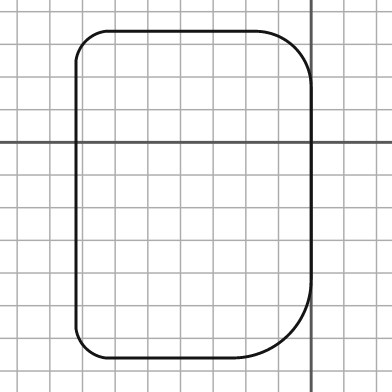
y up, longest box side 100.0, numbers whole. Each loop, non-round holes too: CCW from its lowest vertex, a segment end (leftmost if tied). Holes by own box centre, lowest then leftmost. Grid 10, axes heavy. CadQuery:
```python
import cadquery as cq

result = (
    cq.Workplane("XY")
    .moveTo(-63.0, -66.0)
    .lineTo(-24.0, -66.0)
    .threePointArc((-7.0, -59.0), (0.0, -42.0))
    .lineTo(0.0, 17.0)
    .threePointArc((-5.0, 29.0), (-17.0, 34.0))
    .lineTo(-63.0, 34.0)
    .threePointArc((-69.0, 31.0), (-72.0, 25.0))
    .lineTo(-72.0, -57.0)
    .threePointArc((-69.0, -63.0), (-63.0, -66.0))
    .close()
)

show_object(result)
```